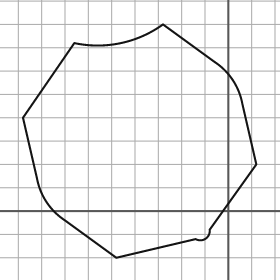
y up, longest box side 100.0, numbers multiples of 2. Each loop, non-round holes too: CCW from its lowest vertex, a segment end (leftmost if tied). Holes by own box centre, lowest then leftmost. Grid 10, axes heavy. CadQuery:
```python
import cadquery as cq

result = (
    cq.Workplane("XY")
    .moveTo(-48.0, -20.0)
    .lineTo(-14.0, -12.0)
    .threePointArc((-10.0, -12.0), (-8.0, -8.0))
    .lineTo(12.0, 20.0)
    .lineTo(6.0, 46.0)
    .threePointArc((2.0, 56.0), (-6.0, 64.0))
    .lineTo(-28.0, 80.0)
    .threePointArc((-46.0, 72.0), (-66.0, 72.0))
    .lineTo(-88.0, 40.0)
    .lineTo(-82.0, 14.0)
    .threePointArc((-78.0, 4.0), (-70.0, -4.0))
    .close()
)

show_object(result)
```